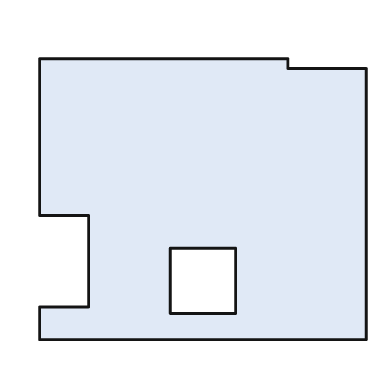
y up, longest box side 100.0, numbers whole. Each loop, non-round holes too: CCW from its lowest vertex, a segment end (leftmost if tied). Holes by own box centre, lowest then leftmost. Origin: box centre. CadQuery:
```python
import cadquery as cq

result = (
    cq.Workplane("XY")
    .moveTo(-50.0, -43.0)
    .lineTo(50.0, -43.0)
    .lineTo(50.0, 40.0)
    .lineTo(26.0, 40.0)
    .lineTo(26.0, 43.0)
    .lineTo(-50.0, 43.0)
    .lineTo(-50.0, -5.0)
    .lineTo(-35.0, -5.0)
    .lineTo(-35.0, -33.0)
    .lineTo(-50.0, -33.0)
    .close()
    .moveTo(-10.0, -35.0)
    .lineTo(10.0, -35.0)
    .lineTo(10.0, -15.0)
    .lineTo(-10.0, -15.0)
    .close()
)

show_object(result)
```